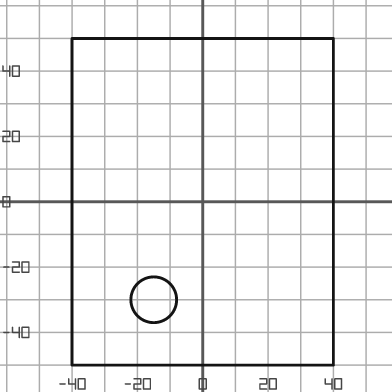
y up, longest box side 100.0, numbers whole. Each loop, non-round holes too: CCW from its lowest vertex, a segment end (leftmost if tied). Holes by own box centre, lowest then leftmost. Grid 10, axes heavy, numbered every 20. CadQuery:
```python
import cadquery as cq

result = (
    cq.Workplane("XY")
    .moveTo(-40.0, -50.0)
    .lineTo(40.0, -50.0)
    .lineTo(40.0, 50.0)
    .lineTo(-40.0, 50.0)
    .close()
    .moveTo(-15.0, -30.0)
    .circle(7.0)
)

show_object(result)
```